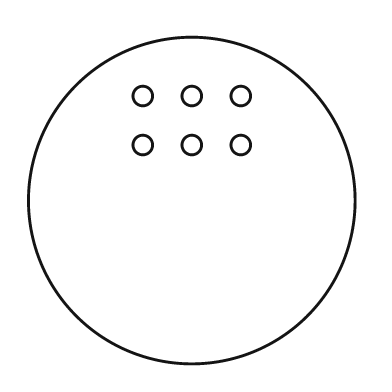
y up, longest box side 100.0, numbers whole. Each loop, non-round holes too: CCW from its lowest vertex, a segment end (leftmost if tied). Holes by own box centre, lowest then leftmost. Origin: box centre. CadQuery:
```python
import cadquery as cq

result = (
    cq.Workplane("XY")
    .moveTo(0.0, 0.0)
    .circle(50.0)
    .moveTo(-15.0, 17.0)
    .circle(3.0)
    .moveTo(0.0, 17.0)
    .circle(3.0)
    .moveTo(15.0, 17.0)
    .circle(3.0)
    .moveTo(-15.0, 32.0)
    .circle(3.0)
    .moveTo(0.0, 32.0)
    .circle(3.0)
    .moveTo(15.0, 32.0)
    .circle(3.0)
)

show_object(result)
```